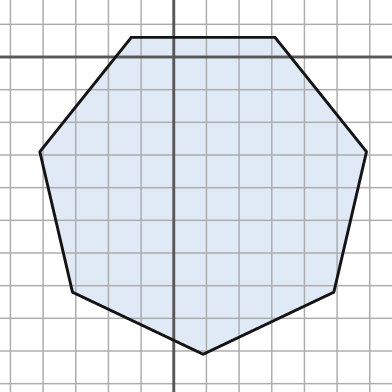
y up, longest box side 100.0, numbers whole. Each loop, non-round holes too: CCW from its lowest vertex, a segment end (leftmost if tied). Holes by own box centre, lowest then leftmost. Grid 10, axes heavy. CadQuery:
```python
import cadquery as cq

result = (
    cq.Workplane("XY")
    .moveTo(9.0, -91.0)
    .lineTo(49.0, -72.0)
    .lineTo(59.0, -29.0)
    .lineTo(31.0, 6.0)
    .lineTo(-13.0, 6.0)
    .lineTo(-41.0, -29.0)
    .lineTo(-31.0, -72.0)
    .close()
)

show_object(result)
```